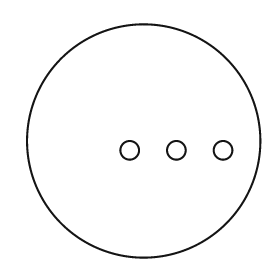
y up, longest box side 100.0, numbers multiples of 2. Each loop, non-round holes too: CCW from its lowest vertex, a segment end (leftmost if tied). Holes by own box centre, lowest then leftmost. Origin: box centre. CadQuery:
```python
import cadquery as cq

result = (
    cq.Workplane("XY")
    .moveTo(0.0, 0.0)
    .circle(50.0)
    .moveTo(-6.0, -4.0)
    .circle(4.0)
    .moveTo(14.0, -4.0)
    .circle(4.0)
    .moveTo(34.0, -4.0)
    .circle(4.0)
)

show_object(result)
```